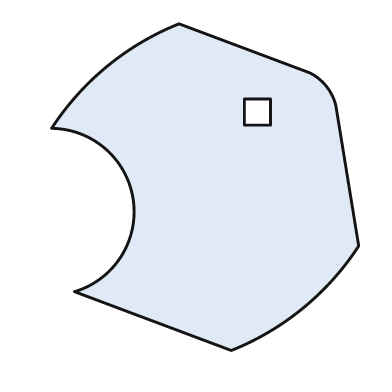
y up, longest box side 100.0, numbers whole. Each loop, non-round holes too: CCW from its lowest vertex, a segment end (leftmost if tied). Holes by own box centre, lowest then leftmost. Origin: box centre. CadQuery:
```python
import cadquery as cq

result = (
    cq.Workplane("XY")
    .moveTo(8.0, -50.0)
    .threePointArc((30.0, -37.0), (47.0, -18.0))
    .lineTo(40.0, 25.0)
    .threePointArc((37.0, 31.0), (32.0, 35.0))
    .lineTo(-8.0, 50.0)
    .threePointArc((-30.0, 37.0), (-47.0, 18.0))
    .threePointArc((-22.0, -4.0), (-40.0, -32.0))
    .close()
    .moveTo(12.0, 19.0)
    .lineTo(20.0, 19.0)
    .lineTo(20.0, 27.0)
    .lineTo(12.0, 27.0)
    .close()
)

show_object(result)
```